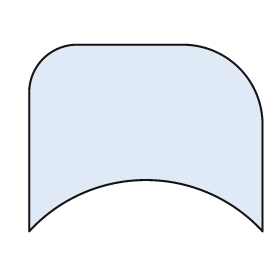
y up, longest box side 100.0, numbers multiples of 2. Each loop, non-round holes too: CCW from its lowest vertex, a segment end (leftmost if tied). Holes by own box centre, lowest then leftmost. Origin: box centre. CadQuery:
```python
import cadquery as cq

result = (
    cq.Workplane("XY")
    .moveTo(-50.0, -40.0)
    .threePointArc((0.0, -18.0), (50.0, -40.0))
    .lineTo(50.0, 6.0)
    .threePointArc((40.0, 30.0), (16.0, 40.0))
    .lineTo(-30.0, 40.0)
    .threePointArc((-44.0, 34.0), (-50.0, 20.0))
    .close()
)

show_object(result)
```